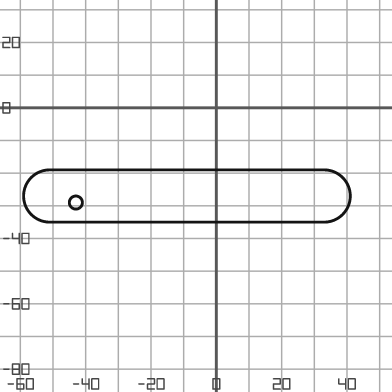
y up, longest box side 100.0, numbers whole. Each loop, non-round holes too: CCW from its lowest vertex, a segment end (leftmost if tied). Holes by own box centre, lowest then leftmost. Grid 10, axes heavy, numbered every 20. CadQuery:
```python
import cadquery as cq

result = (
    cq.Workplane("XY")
    .moveTo(-51.0, -35.0)
    .lineTo(33.0, -35.0)
    .threePointArc((41.0, -27.0), (33.0, -19.0))
    .lineTo(-51.0, -19.0)
    .threePointArc((-59.0, -27.0), (-51.0, -35.0))
    .close()
    .moveTo(-43.0, -29.0)
    .circle(2.0)
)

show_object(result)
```